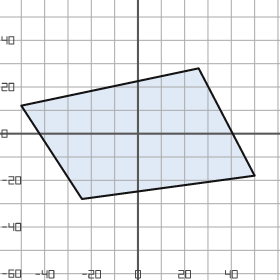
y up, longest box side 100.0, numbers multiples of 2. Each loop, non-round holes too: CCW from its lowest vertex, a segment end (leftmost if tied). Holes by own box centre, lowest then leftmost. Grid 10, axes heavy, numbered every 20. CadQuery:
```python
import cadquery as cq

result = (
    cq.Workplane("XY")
    .moveTo(-24.0, -28.0)
    .lineTo(50.0, -18.0)
    .lineTo(26.0, 28.0)
    .lineTo(-50.0, 12.0)
    .close()
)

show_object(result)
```